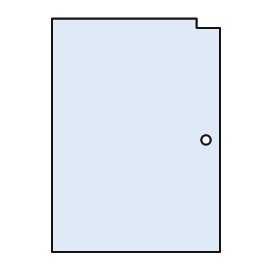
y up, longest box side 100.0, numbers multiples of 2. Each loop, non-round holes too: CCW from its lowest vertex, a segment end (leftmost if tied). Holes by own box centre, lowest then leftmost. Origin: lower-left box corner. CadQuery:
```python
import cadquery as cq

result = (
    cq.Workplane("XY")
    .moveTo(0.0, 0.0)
    .lineTo(72.0, 0.0)
    .lineTo(72.0, 96.0)
    .lineTo(62.0, 96.0)
    .lineTo(62.0, 100.0)
    .lineTo(0.0, 100.0)
    .close()
    .moveTo(66.0, 48.0)
    .circle(2.0)
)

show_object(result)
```